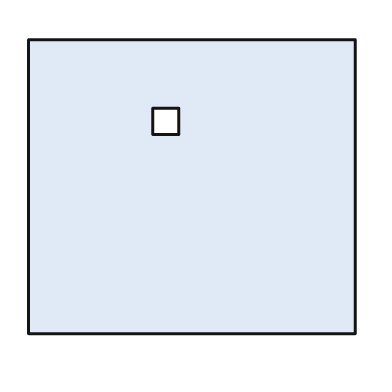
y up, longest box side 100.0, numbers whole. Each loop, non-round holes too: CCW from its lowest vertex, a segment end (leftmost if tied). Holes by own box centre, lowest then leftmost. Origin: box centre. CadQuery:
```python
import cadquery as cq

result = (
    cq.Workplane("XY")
    .moveTo(-50.0, -45.0)
    .lineTo(50.0, -45.0)
    .lineTo(50.0, 45.0)
    .lineTo(-50.0, 45.0)
    .close()
    .moveTo(-12.0, 16.0)
    .lineTo(-4.0, 16.0)
    .lineTo(-4.0, 24.0)
    .lineTo(-12.0, 24.0)
    .close()
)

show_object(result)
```